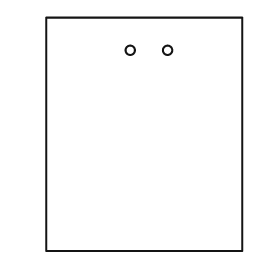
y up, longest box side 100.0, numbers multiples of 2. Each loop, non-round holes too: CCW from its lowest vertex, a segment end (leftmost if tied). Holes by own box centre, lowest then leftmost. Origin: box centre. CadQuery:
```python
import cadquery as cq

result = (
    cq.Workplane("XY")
    .moveTo(-42.0, -50.0)
    .lineTo(42.0, -50.0)
    .lineTo(42.0, 50.0)
    .lineTo(-42.0, 50.0)
    .close()
    .moveTo(-6.0, 36.0)
    .circle(2.0)
    .moveTo(10.0, 36.0)
    .circle(2.0)
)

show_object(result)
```